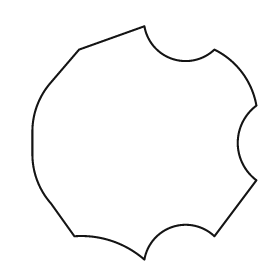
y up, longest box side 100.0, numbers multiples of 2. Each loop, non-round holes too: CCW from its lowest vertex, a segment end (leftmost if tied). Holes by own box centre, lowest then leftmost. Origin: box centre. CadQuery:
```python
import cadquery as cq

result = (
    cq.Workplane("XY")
    .moveTo(0.0, -50.0)
    .threePointArc((12.0, -36.0), (30.0, -40.0))
    .lineTo(48.0, -16.0)
    .threePointArc((40.0, 0.0), (48.0, 16.0))
    .threePointArc((42.0, 30.0), (30.0, 40.0))
    .threePointArc((12.0, 36.0), (0.0, 50.0))
    .lineTo(-28.0, 40.0)
    .lineTo(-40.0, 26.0)
    .threePointArc((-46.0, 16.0), (-48.0, 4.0))
    .lineTo(-48.0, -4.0)
    .threePointArc((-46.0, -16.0), (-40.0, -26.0))
    .lineTo(-30.0, -40.0)
    .threePointArc((-14.0, -42.0), (0.0, -50.0))
    .close()
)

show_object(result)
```